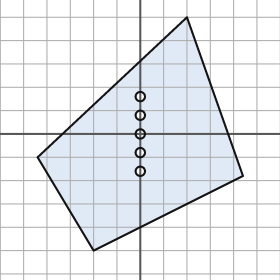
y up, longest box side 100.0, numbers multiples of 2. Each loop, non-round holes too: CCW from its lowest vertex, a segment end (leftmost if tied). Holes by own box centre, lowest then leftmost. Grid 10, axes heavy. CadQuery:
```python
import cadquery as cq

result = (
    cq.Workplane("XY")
    .moveTo(-20.0, -50.0)
    .lineTo(44.0, -18.0)
    .lineTo(20.0, 50.0)
    .lineTo(-44.0, -10.0)
    .close()
    .moveTo(0.0, -16.0)
    .circle(2.0)
    .moveTo(0.0, -8.0)
    .circle(2.0)
    .moveTo(0.0, 0.0)
    .circle(2.0)
    .moveTo(0.0, 8.0)
    .circle(2.0)
    .moveTo(0.0, 16.0)
    .circle(2.0)
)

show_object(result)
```